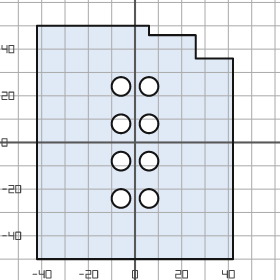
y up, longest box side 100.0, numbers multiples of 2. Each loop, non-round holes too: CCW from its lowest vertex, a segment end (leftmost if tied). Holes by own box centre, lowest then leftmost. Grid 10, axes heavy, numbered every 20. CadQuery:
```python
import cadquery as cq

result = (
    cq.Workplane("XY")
    .moveTo(-42.0, -50.0)
    .lineTo(42.0, -50.0)
    .lineTo(42.0, 36.0)
    .lineTo(26.0, 36.0)
    .lineTo(26.0, 46.0)
    .lineTo(6.0, 46.0)
    .lineTo(6.0, 50.0)
    .lineTo(-42.0, 50.0)
    .close()
    .moveTo(-6.0, -24.0)
    .circle(4.0)
    .moveTo(6.0, -24.0)
    .circle(4.0)
    .moveTo(-6.0, -8.0)
    .circle(4.0)
    .moveTo(6.0, -8.0)
    .circle(4.0)
    .moveTo(-6.0, 8.0)
    .circle(4.0)
    .moveTo(6.0, 8.0)
    .circle(4.0)
    .moveTo(-6.0, 24.0)
    .circle(4.0)
    .moveTo(6.0, 24.0)
    .circle(4.0)
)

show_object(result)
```